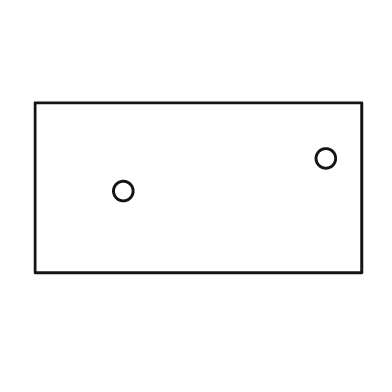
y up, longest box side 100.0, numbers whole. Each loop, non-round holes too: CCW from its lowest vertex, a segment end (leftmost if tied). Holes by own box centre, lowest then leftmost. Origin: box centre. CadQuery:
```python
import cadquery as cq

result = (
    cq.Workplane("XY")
    .moveTo(-50.0, -26.0)
    .lineTo(50.0, -26.0)
    .lineTo(50.0, 26.0)
    .lineTo(-50.0, 26.0)
    .close()
    .moveTo(-23.0, -1.0)
    .circle(3.0)
    .moveTo(39.0, 9.0)
    .circle(3.0)
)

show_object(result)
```